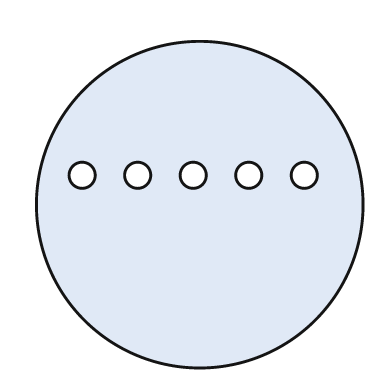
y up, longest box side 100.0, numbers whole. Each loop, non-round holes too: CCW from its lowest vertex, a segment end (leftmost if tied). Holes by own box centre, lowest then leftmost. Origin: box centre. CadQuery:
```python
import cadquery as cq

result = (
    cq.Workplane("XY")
    .moveTo(0.0, 0.0)
    .circle(50.0)
    .moveTo(-36.0, 9.0)
    .circle(4.0)
    .moveTo(-19.0, 9.0)
    .circle(4.0)
    .moveTo(-2.0, 9.0)
    .circle(4.0)
    .moveTo(15.0, 9.0)
    .circle(4.0)
    .moveTo(32.0, 9.0)
    .circle(4.0)
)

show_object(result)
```